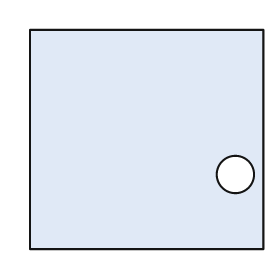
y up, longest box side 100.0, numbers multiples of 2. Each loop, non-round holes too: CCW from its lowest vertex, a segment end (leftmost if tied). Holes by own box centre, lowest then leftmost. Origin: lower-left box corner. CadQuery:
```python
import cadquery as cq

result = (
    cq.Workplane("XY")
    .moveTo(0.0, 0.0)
    .lineTo(100.0, 0.0)
    .lineTo(100.0, 94.0)
    .lineTo(0.0, 94.0)
    .close()
    .moveTo(88.0, 32.0)
    .circle(8.0)
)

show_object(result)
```